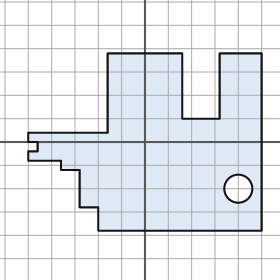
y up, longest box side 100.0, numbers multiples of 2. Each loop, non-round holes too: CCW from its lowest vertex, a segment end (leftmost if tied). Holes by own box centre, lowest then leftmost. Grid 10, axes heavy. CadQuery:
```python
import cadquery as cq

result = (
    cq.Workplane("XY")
    .moveTo(-20.0, -38.0)
    .lineTo(50.0, -38.0)
    .lineTo(50.0, 38.0)
    .lineTo(32.0, 38.0)
    .lineTo(32.0, 10.0)
    .lineTo(16.0, 10.0)
    .lineTo(16.0, 38.0)
    .lineTo(-16.0, 38.0)
    .lineTo(-16.0, 4.0)
    .lineTo(-50.0, 4.0)
    .lineTo(-50.0, 0.0)
    .lineTo(-46.0, 0.0)
    .lineTo(-46.0, -4.0)
    .lineTo(-50.0, -4.0)
    .lineTo(-50.0, -8.0)
    .lineTo(-36.0, -8.0)
    .lineTo(-36.0, -12.0)
    .lineTo(-28.0, -12.0)
    .lineTo(-28.0, -28.0)
    .lineTo(-20.0, -28.0)
    .close()
    .moveTo(40.0, -20.0)
    .circle(6.0)
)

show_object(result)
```